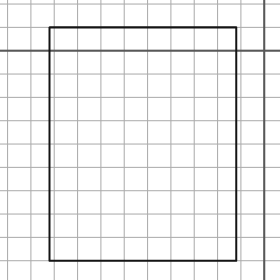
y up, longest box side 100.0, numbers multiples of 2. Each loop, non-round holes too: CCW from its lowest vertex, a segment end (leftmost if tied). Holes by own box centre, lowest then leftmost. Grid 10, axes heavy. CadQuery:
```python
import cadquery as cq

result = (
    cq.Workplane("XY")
    .moveTo(-92.0, -90.0)
    .lineTo(-12.0, -90.0)
    .lineTo(-12.0, 10.0)
    .lineTo(-92.0, 10.0)
    .close()
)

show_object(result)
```